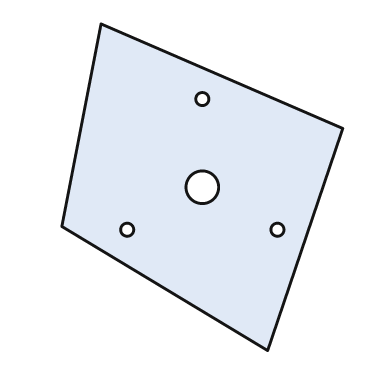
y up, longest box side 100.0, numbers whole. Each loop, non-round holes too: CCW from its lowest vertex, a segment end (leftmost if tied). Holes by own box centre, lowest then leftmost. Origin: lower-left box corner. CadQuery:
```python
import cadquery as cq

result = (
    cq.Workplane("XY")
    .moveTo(63.0, 0.0)
    .lineTo(86.0, 68.0)
    .lineTo(12.0, 100.0)
    .lineTo(0.0, 38.0)
    .close()
    .moveTo(20.0, 37.0)
    .circle(2.0)
    .moveTo(66.0, 37.0)
    .circle(2.0)
    .moveTo(43.0, 50.0)
    .circle(5.0)
    .moveTo(43.0, 77.0)
    .circle(2.0)
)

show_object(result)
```